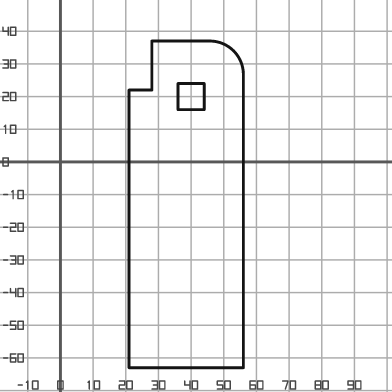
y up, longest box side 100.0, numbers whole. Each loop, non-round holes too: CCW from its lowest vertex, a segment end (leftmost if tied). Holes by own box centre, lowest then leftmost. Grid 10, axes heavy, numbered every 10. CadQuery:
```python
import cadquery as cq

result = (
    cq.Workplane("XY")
    .moveTo(21.0, -63.0)
    .lineTo(56.0, -63.0)
    .lineTo(56.0, 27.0)
    .threePointArc((53.0, 34.0), (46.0, 37.0))
    .lineTo(28.0, 37.0)
    .lineTo(28.0, 22.0)
    .lineTo(21.0, 22.0)
    .close()
    .moveTo(36.0, 16.0)
    .lineTo(44.0, 16.0)
    .lineTo(44.0, 24.0)
    .lineTo(36.0, 24.0)
    .close()
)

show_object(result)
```